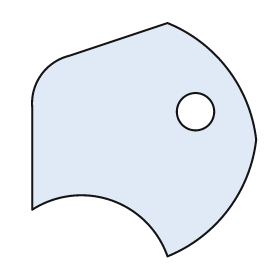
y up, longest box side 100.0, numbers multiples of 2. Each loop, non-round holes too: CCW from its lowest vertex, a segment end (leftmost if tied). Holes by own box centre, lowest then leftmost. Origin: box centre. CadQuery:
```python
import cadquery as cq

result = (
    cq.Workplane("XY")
    .moveTo(10.0, -50.0)
    .threePointArc((36.0, -30.0), (48.0, 0.0))
    .threePointArc((36.0, 30.0), (10.0, 50.0))
    .lineTo(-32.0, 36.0)
    .threePointArc((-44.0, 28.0), (-48.0, 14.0))
    .lineTo(-48.0, -30.0)
    .threePointArc((-14.0, -26.0), (10.0, -50.0))
    .close()
    .moveTo(22.0, 12.0)
    .circle(8.0)
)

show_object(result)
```